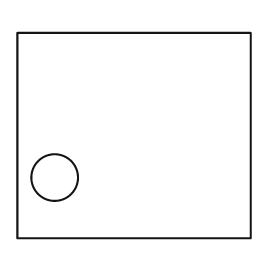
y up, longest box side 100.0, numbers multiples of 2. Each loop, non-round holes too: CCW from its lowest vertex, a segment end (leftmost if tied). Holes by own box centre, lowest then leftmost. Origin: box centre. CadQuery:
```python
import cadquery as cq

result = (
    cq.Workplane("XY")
    .moveTo(-50.0, -44.0)
    .lineTo(50.0, -44.0)
    .lineTo(50.0, 44.0)
    .lineTo(-50.0, 44.0)
    .close()
    .moveTo(-34.0, -18.0)
    .circle(10.0)
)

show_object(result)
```